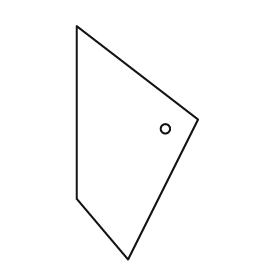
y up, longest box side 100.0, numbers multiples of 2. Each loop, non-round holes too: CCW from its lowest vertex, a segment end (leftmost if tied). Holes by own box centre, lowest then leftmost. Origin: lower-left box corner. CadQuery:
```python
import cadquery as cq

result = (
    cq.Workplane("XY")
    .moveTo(22.0, 0.0)
    .lineTo(52.0, 60.0)
    .lineTo(0.0, 100.0)
    .lineTo(0.0, 26.0)
    .close()
    .moveTo(38.0, 56.0)
    .circle(2.0)
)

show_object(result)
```